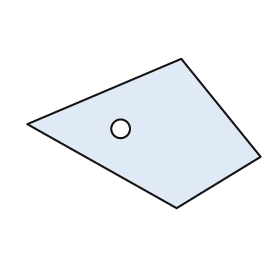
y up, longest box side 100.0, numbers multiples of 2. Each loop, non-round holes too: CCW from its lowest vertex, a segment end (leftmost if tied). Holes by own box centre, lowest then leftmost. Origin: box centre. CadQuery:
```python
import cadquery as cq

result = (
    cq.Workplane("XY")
    .moveTo(14.0, -32.0)
    .lineTo(50.0, -10.0)
    .lineTo(16.0, 32.0)
    .lineTo(-50.0, 4.0)
    .close()
    .moveTo(-10.0, 2.0)
    .circle(4.0)
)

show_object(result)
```